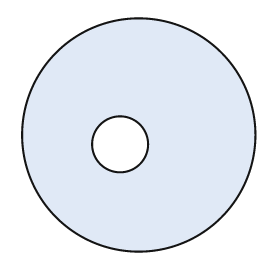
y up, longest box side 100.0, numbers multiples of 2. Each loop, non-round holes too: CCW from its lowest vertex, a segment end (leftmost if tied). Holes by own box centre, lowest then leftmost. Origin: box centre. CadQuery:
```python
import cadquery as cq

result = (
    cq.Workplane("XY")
    .moveTo(0.0, 0.0)
    .circle(50.0)
    .moveTo(-8.0, -4.0)
    .circle(12.0)
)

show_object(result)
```